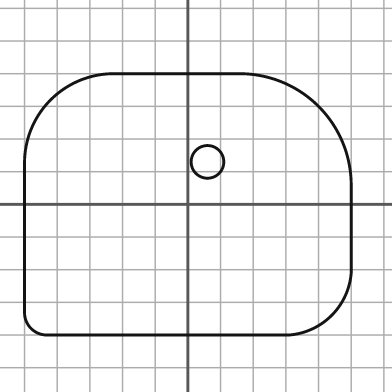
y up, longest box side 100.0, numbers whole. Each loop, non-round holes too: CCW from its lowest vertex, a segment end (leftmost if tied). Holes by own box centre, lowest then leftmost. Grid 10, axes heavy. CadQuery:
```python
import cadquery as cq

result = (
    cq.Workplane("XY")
    .moveTo(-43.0, -40.0)
    .lineTo(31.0, -40.0)
    .threePointArc((44.0, -34.0), (50.0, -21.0))
    .lineTo(50.0, 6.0)
    .threePointArc((40.0, 30.0), (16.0, 40.0))
    .lineTo(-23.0, 40.0)
    .threePointArc((-42.0, 32.0), (-50.0, 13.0))
    .lineTo(-50.0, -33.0)
    .threePointArc((-48.0, -38.0), (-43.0, -40.0))
    .close()
    .moveTo(6.0, 13.0)
    .circle(5.0)
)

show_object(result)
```